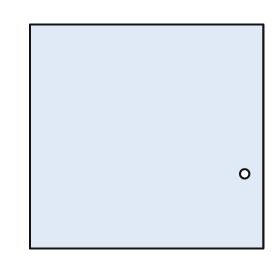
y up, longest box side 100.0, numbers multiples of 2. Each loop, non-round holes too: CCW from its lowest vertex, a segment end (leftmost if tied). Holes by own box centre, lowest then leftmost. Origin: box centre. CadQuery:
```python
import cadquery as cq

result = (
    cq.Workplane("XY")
    .moveTo(-50.0, -48.0)
    .lineTo(50.0, -48.0)
    .lineTo(50.0, 48.0)
    .lineTo(-50.0, 48.0)
    .close()
    .moveTo(42.0, -16.0)
    .circle(2.0)
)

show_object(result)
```